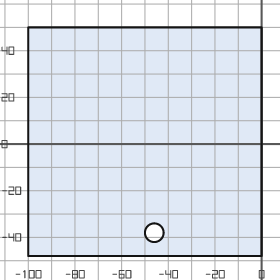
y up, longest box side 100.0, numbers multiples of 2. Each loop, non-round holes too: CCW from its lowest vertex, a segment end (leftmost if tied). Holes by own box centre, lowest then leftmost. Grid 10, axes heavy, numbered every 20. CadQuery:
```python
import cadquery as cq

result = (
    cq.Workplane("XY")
    .moveTo(-100.0, -48.0)
    .lineTo(0.0, -48.0)
    .lineTo(0.0, 50.0)
    .lineTo(-100.0, 50.0)
    .close()
    .moveTo(-46.0, -38.0)
    .circle(4.0)
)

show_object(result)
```